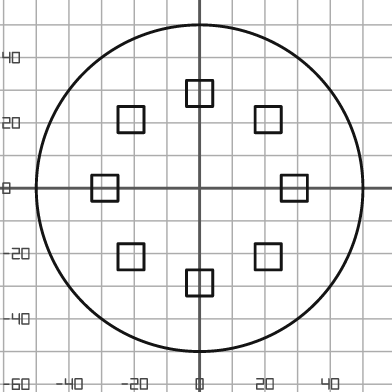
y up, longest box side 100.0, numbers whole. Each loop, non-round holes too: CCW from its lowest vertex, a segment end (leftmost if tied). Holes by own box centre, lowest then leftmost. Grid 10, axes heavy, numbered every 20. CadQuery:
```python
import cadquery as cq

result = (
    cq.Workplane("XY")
    .moveTo(0.0, 0.0)
    .circle(50.0)
    .moveTo(-4.0, -33.0)
    .lineTo(4.0, -33.0)
    .lineTo(4.0, -25.0)
    .lineTo(-4.0, -25.0)
    .close()
    .moveTo(-25.0, -25.0)
    .lineTo(-17.0, -25.0)
    .lineTo(-17.0, -17.0)
    .lineTo(-25.0, -17.0)
    .close()
    .moveTo(17.0, -25.0)
    .lineTo(25.0, -25.0)
    .lineTo(25.0, -17.0)
    .lineTo(17.0, -17.0)
    .close()
    .moveTo(-33.0, -4.0)
    .lineTo(-25.0, -4.0)
    .lineTo(-25.0, 4.0)
    .lineTo(-33.0, 4.0)
    .close()
    .moveTo(25.0, -4.0)
    .lineTo(33.0, -4.0)
    .lineTo(33.0, 4.0)
    .lineTo(25.0, 4.0)
    .close()
    .moveTo(-25.0, 17.0)
    .lineTo(-17.0, 17.0)
    .lineTo(-17.0, 25.0)
    .lineTo(-25.0, 25.0)
    .close()
    .moveTo(17.0, 17.0)
    .lineTo(25.0, 17.0)
    .lineTo(25.0, 25.0)
    .lineTo(17.0, 25.0)
    .close()
    .moveTo(-4.0, 25.0)
    .lineTo(4.0, 25.0)
    .lineTo(4.0, 33.0)
    .lineTo(-4.0, 33.0)
    .close()
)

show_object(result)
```